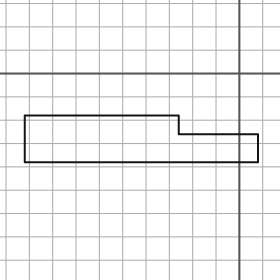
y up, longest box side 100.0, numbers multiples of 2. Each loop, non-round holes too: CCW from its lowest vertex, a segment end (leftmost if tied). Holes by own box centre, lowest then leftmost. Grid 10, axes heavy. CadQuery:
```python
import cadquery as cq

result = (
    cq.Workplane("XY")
    .moveTo(-92.0, -38.0)
    .lineTo(8.0, -38.0)
    .lineTo(8.0, -26.0)
    .lineTo(-26.0, -26.0)
    .lineTo(-26.0, -18.0)
    .lineTo(-92.0, -18.0)
    .close()
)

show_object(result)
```